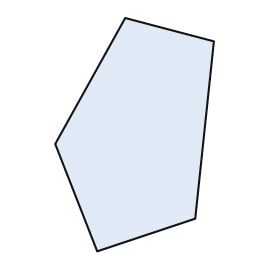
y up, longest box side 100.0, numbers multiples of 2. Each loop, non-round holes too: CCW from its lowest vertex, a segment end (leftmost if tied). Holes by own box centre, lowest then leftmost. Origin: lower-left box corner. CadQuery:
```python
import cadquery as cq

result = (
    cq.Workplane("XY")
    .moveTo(18.0, 0.0)
    .lineTo(60.0, 14.0)
    .lineTo(68.0, 90.0)
    .lineTo(30.0, 100.0)
    .lineTo(0.0, 46.0)
    .close()
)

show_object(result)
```